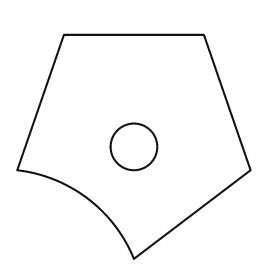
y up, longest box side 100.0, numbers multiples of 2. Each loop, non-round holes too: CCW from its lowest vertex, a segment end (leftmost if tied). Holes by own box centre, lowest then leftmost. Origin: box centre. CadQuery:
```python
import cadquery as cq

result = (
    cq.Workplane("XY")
    .moveTo(0.0, -48.0)
    .lineTo(50.0, -10.0)
    .lineTo(30.0, 48.0)
    .lineTo(-30.0, 48.0)
    .lineTo(-50.0, -10.0)
    .threePointArc((-20.0, -22.0), (0.0, -48.0))
    .close()
    .moveTo(0.0, 0.0)
    .circle(10.0)
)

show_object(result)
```